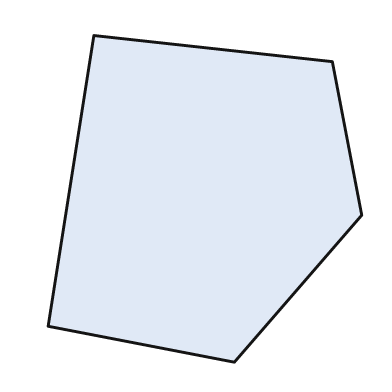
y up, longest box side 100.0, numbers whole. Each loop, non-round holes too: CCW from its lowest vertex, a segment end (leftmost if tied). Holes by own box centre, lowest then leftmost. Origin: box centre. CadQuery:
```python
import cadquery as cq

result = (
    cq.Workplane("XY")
    .moveTo(9.0, -50.0)
    .lineTo(48.0, -5.0)
    .lineTo(39.0, 42.0)
    .lineTo(-34.0, 50.0)
    .lineTo(-48.0, -39.0)
    .close()
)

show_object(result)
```